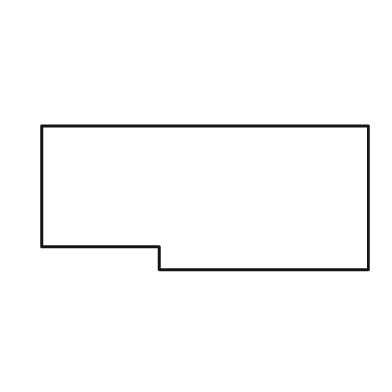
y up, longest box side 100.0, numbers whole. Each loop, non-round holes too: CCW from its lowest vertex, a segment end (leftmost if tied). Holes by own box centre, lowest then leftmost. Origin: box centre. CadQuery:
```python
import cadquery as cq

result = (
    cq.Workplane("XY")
    .moveTo(-14.0, -22.0)
    .lineTo(50.0, -22.0)
    .lineTo(50.0, 22.0)
    .lineTo(-50.0, 22.0)
    .lineTo(-50.0, -15.0)
    .lineTo(-14.0, -15.0)
    .close()
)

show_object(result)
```